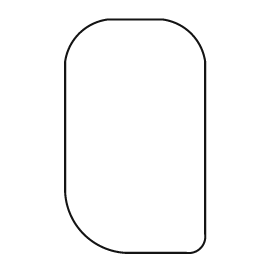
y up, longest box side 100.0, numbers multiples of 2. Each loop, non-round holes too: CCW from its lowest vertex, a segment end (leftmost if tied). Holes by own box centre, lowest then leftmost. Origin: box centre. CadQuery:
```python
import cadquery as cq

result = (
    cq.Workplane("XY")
    .moveTo(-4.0, -50.0)
    .lineTo(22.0, -50.0)
    .threePointArc((28.0, -48.0), (30.0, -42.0))
    .lineTo(30.0, 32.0)
    .threePointArc((24.0, 44.0), (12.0, 50.0))
    .lineTo(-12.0, 50.0)
    .threePointArc((-24.0, 44.0), (-30.0, 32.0))
    .lineTo(-30.0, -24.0)
    .threePointArc((-22.0, -42.0), (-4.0, -50.0))
    .close()
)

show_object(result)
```